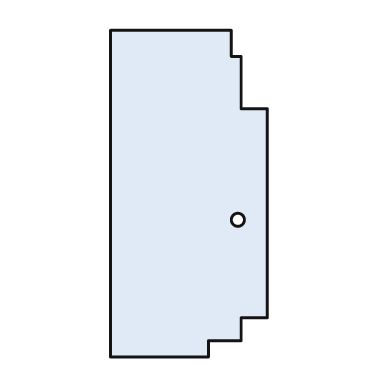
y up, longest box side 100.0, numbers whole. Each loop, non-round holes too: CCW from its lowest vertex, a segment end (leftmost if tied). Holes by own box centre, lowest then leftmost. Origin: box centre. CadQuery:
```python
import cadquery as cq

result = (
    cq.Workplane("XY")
    .moveTo(-24.0, -50.0)
    .lineTo(6.0, -50.0)
    .lineTo(6.0, -45.0)
    .lineTo(16.0, -45.0)
    .lineTo(16.0, -38.0)
    .lineTo(24.0, -38.0)
    .lineTo(24.0, 26.0)
    .lineTo(16.0, 26.0)
    .lineTo(16.0, 42.0)
    .lineTo(13.0, 42.0)
    .lineTo(13.0, 50.0)
    .lineTo(-24.0, 50.0)
    .close()
    .moveTo(15.0, -8.0)
    .circle(2.0)
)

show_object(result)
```